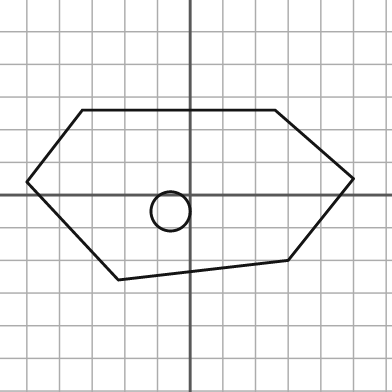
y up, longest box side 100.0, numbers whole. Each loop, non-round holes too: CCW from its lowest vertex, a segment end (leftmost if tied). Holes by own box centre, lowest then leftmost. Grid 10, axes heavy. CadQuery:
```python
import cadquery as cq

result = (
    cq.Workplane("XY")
    .moveTo(-22.0, -26.0)
    .lineTo(30.0, -20.0)
    .lineTo(50.0, 5.0)
    .lineTo(26.0, 26.0)
    .lineTo(-33.0, 26.0)
    .lineTo(-50.0, 4.0)
    .close()
    .moveTo(-6.0, -5.0)
    .circle(6.0)
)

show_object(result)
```